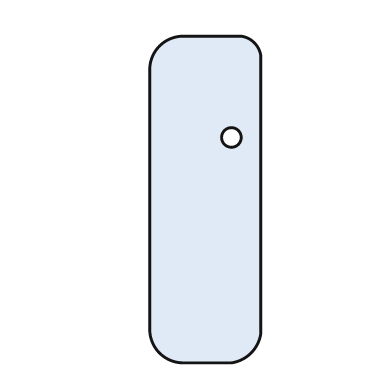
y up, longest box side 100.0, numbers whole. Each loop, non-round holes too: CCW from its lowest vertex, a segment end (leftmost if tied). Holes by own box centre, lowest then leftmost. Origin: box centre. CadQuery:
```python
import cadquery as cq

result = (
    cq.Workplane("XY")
    .moveTo(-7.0, -50.0)
    .lineTo(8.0, -50.0)
    .threePointArc((14.0, -47.0), (17.0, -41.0))
    .lineTo(17.0, 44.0)
    .threePointArc((15.0, 48.0), (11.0, 50.0))
    .lineTo(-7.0, 50.0)
    .threePointArc((-14.0, 47.0), (-17.0, 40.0))
    .lineTo(-17.0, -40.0)
    .threePointArc((-14.0, -47.0), (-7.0, -50.0))
    .close()
    .moveTo(8.0, 19.0)
    .circle(3.0)
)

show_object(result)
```